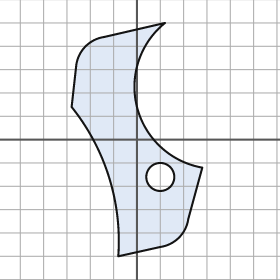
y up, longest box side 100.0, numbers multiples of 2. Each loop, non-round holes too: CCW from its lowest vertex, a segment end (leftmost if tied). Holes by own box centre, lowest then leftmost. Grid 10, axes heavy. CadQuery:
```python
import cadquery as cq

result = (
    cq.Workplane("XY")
    .moveTo(-8.0, -50.0)
    .lineTo(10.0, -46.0)
    .threePointArc((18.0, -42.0), (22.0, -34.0))
    .lineTo(28.0, -12.0)
    .threePointArc((0.0, 14.0), (12.0, 50.0))
    .lineTo(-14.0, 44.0)
    .threePointArc((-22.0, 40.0), (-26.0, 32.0))
    .lineTo(-28.0, 14.0)
    .threePointArc((-12.0, -16.0), (-8.0, -50.0))
    .close()
    .moveTo(10.0, -16.0)
    .circle(6.0)
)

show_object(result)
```